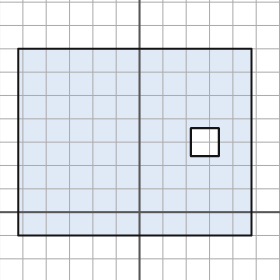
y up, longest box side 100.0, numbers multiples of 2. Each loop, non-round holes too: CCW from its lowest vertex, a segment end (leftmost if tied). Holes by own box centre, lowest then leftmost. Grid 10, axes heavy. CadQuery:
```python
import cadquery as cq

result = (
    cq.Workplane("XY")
    .moveTo(-52.0, -10.0)
    .lineTo(48.0, -10.0)
    .lineTo(48.0, 70.0)
    .lineTo(-52.0, 70.0)
    .close()
    .moveTo(22.0, 24.0)
    .lineTo(34.0, 24.0)
    .lineTo(34.0, 36.0)
    .lineTo(22.0, 36.0)
    .close()
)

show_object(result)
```